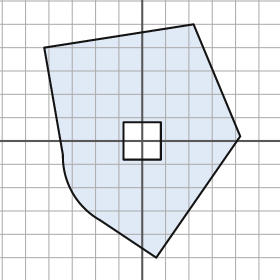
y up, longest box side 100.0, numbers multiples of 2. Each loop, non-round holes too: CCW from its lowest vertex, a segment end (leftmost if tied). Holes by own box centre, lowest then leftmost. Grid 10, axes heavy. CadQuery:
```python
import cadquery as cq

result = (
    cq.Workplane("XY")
    .moveTo(6.0, -50.0)
    .lineTo(42.0, 2.0)
    .lineTo(22.0, 50.0)
    .lineTo(-42.0, 40.0)
    .lineTo(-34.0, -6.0)
    .threePointArc((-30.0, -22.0), (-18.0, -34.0))
    .close()
    .moveTo(-8.0, -8.0)
    .lineTo(8.0, -8.0)
    .lineTo(8.0, 8.0)
    .lineTo(-8.0, 8.0)
    .close()
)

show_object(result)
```